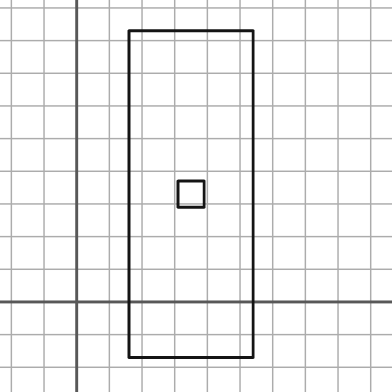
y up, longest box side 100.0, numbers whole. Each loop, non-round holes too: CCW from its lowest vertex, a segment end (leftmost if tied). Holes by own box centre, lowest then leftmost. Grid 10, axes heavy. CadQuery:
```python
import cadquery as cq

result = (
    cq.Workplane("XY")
    .moveTo(16.0, -17.0)
    .lineTo(54.0, -17.0)
    .lineTo(54.0, 83.0)
    .lineTo(16.0, 83.0)
    .close()
    .moveTo(31.0, 29.0)
    .lineTo(39.0, 29.0)
    .lineTo(39.0, 37.0)
    .lineTo(31.0, 37.0)
    .close()
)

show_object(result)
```